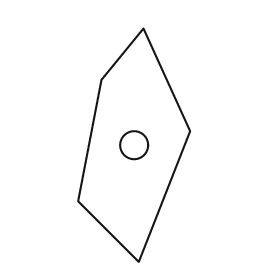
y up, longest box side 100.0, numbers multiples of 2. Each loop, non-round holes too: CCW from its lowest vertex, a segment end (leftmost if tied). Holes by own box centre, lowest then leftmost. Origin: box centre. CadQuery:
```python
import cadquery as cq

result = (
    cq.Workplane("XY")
    .moveTo(2.0, -50.0)
    .lineTo(24.0, 6.0)
    .lineTo(4.0, 50.0)
    .lineTo(-14.0, 28.0)
    .lineTo(-24.0, -24.0)
    .close()
    .moveTo(0.0, 0.0)
    .circle(6.0)
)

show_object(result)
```